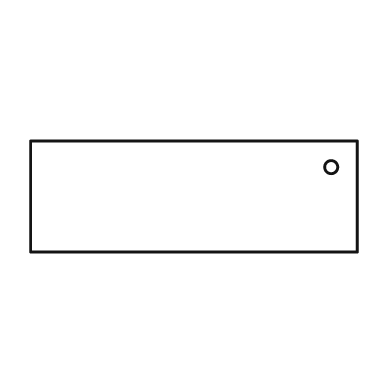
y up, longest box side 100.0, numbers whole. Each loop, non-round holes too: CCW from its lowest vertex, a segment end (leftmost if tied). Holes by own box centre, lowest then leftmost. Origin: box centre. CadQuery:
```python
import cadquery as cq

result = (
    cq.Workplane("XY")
    .moveTo(-50.0, -17.0)
    .lineTo(50.0, -17.0)
    .lineTo(50.0, 17.0)
    .lineTo(-50.0, 17.0)
    .close()
    .moveTo(42.0, 9.0)
    .circle(2.0)
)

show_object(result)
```